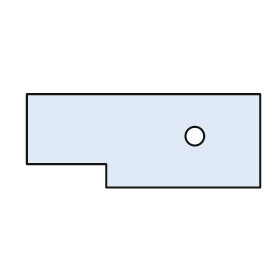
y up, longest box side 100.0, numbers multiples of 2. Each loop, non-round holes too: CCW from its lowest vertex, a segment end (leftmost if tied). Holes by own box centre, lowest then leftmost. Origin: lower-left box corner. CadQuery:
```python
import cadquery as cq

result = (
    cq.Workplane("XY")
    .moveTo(34.0, 0.0)
    .lineTo(100.0, 0.0)
    .lineTo(100.0, 40.0)
    .lineTo(0.0, 40.0)
    .lineTo(0.0, 10.0)
    .lineTo(34.0, 10.0)
    .close()
    .moveTo(72.0, 22.0)
    .circle(4.0)
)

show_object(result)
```